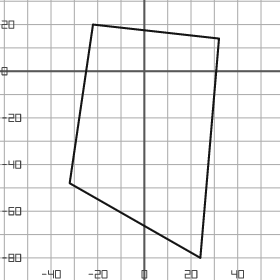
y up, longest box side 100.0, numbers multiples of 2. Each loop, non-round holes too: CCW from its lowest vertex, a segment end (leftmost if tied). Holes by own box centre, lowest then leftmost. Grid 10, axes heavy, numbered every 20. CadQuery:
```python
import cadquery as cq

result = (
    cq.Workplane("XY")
    .moveTo(24.0, -80.0)
    .lineTo(32.0, 14.0)
    .lineTo(-22.0, 20.0)
    .lineTo(-32.0, -48.0)
    .close()
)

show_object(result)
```